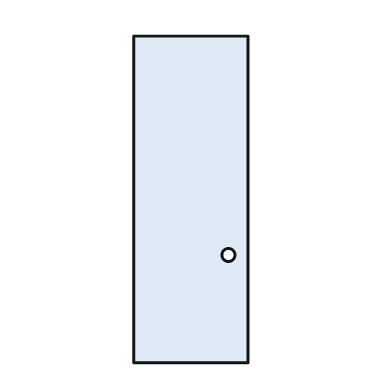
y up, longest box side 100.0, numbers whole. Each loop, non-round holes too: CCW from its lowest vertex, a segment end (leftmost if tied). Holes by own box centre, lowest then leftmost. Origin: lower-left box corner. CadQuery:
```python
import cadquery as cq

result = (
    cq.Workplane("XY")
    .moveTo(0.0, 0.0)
    .lineTo(35.0, 0.0)
    .lineTo(35.0, 100.0)
    .lineTo(0.0, 100.0)
    .close()
    .moveTo(29.0, 33.0)
    .circle(2.0)
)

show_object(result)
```